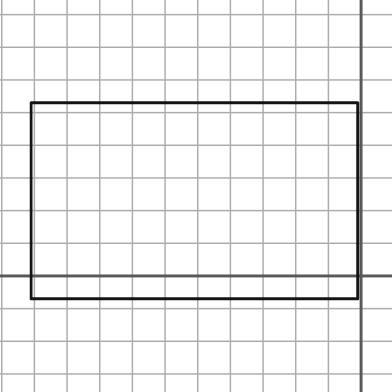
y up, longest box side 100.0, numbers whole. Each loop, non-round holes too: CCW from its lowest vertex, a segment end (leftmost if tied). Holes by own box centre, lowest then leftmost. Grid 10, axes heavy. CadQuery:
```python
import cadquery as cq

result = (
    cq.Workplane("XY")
    .moveTo(-101.0, -7.0)
    .lineTo(-1.0, -7.0)
    .lineTo(-1.0, 53.0)
    .lineTo(-101.0, 53.0)
    .close()
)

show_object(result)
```